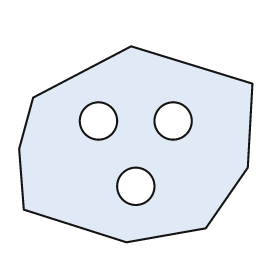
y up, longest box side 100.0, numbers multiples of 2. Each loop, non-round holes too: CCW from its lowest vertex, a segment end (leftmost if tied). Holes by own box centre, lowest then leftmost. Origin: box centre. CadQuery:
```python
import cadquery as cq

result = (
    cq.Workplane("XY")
    .moveTo(-4.0, -42.0)
    .lineTo(30.0, -36.0)
    .lineTo(48.0, -10.0)
    .lineTo(50.0, 26.0)
    .lineTo(-2.0, 42.0)
    .lineTo(-44.0, 20.0)
    .lineTo(-50.0, -2.0)
    .lineTo(-48.0, -28.0)
    .close()
    .moveTo(0.0, -18.0)
    .circle(8.0)
    .moveTo(-16.0, 10.0)
    .circle(8.0)
    .moveTo(16.0, 10.0)
    .circle(8.0)
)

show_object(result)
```